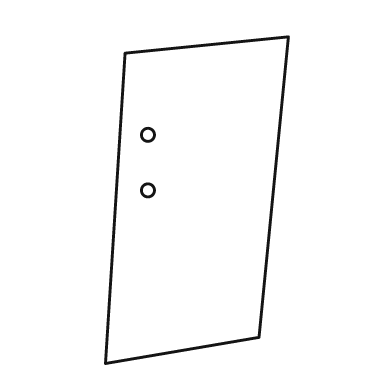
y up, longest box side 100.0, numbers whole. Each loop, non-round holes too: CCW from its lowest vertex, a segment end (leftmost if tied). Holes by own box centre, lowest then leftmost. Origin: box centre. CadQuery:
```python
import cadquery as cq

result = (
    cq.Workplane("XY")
    .moveTo(-28.0, -50.0)
    .lineTo(19.0, -42.0)
    .lineTo(28.0, 50.0)
    .lineTo(-22.0, 45.0)
    .close()
    .moveTo(-15.0, 3.0)
    .circle(2.0)
    .moveTo(-15.0, 20.0)
    .circle(2.0)
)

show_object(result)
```